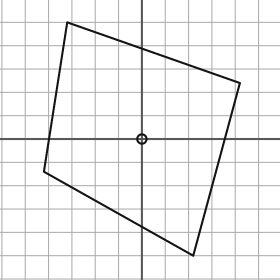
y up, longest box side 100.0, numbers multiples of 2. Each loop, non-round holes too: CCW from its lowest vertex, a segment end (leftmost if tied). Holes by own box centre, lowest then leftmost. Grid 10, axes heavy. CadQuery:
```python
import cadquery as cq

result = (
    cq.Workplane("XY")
    .moveTo(22.0, -50.0)
    .lineTo(42.0, 24.0)
    .lineTo(-32.0, 50.0)
    .lineTo(-42.0, -14.0)
    .close()
    .moveTo(0.0, 0.0)
    .circle(2.0)
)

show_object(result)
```